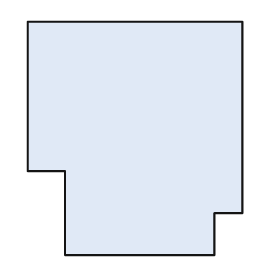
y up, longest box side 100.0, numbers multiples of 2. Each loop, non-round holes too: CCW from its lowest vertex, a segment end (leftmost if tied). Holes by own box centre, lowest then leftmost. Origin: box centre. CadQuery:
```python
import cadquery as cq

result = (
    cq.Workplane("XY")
    .moveTo(-30.0, -50.0)
    .lineTo(34.0, -50.0)
    .lineTo(34.0, -32.0)
    .lineTo(46.0, -32.0)
    .lineTo(46.0, 50.0)
    .lineTo(-46.0, 50.0)
    .lineTo(-46.0, -14.0)
    .lineTo(-30.0, -14.0)
    .close()
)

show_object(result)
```